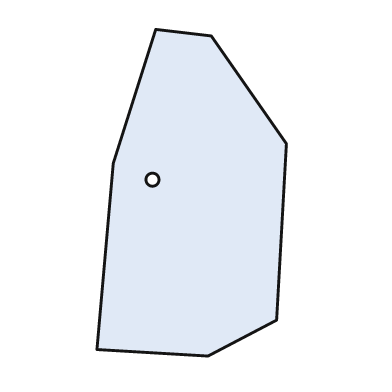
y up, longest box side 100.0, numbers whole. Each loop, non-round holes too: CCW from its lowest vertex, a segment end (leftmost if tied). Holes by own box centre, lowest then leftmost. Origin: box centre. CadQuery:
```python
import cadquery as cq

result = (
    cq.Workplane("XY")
    .moveTo(5.0, -50.0)
    .lineTo(26.0, -39.0)
    .lineTo(29.0, 15.0)
    .lineTo(6.0, 48.0)
    .lineTo(-11.0, 50.0)
    .lineTo(-24.0, 9.0)
    .lineTo(-29.0, -48.0)
    .close()
    .moveTo(-12.0, 4.0)
    .circle(2.0)
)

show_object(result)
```